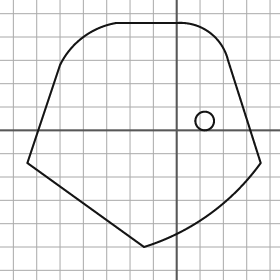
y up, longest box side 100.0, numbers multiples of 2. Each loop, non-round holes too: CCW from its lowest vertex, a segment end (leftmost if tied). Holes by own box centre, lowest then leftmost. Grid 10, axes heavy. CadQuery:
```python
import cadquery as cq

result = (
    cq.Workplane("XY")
    .moveTo(-14.0, -50.0)
    .threePointArc((14.0, -36.0), (36.0, -14.0))
    .lineTo(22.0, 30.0)
    .threePointArc((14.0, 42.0), (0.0, 46.0))
    .lineTo(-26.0, 46.0)
    .threePointArc((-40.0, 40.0), (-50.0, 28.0))
    .lineTo(-64.0, -14.0)
    .close()
    .moveTo(12.0, 4.0)
    .circle(4.0)
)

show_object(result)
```